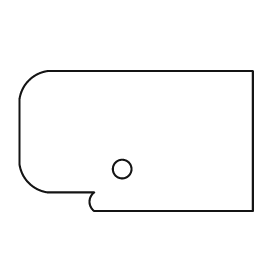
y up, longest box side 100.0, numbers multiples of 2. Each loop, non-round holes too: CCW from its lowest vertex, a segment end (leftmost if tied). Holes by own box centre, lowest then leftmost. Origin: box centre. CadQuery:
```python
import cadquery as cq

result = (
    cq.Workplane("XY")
    .moveTo(-18.0, -30.0)
    .lineTo(50.0, -30.0)
    .lineTo(50.0, 30.0)
    .lineTo(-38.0, 30.0)
    .threePointArc((-46.0, 26.0), (-50.0, 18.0))
    .lineTo(-50.0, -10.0)
    .threePointArc((-46.0, -18.0), (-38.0, -22.0))
    .lineTo(-18.0, -22.0)
    .threePointArc((-20.0, -26.0), (-18.0, -30.0))
    .close()
    .moveTo(-6.0, -12.0)
    .circle(4.0)
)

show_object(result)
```